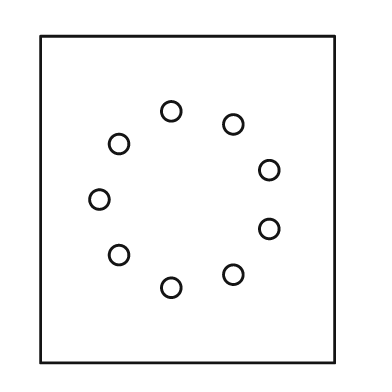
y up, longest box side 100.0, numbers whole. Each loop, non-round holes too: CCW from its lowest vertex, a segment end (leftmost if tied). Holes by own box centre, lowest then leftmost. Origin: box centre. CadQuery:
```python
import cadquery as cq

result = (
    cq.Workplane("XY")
    .moveTo(-45.0, -50.0)
    .lineTo(45.0, -50.0)
    .lineTo(45.0, 50.0)
    .lineTo(-45.0, 50.0)
    .close()
    .moveTo(-5.0, -27.0)
    .circle(3.0)
    .moveTo(14.0, -23.0)
    .circle(3.0)
    .moveTo(-21.0, -17.0)
    .circle(3.0)
    .moveTo(25.0, -9.0)
    .circle(3.0)
    .moveTo(-27.0, 0.0)
    .circle(3.0)
    .moveTo(25.0, 9.0)
    .circle(3.0)
    .moveTo(-21.0, 17.0)
    .circle(3.0)
    .moveTo(14.0, 23.0)
    .circle(3.0)
    .moveTo(-5.0, 27.0)
    .circle(3.0)
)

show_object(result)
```